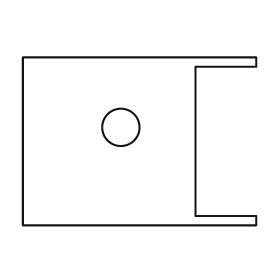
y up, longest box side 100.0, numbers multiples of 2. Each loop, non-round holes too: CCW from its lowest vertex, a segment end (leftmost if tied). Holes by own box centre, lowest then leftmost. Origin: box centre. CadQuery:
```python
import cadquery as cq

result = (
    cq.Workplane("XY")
    .moveTo(-50.0, -36.0)
    .lineTo(50.0, -36.0)
    .lineTo(50.0, -32.0)
    .lineTo(24.0, -32.0)
    .lineTo(24.0, 32.0)
    .lineTo(50.0, 32.0)
    .lineTo(50.0, 36.0)
    .lineTo(-50.0, 36.0)
    .close()
    .moveTo(-8.0, 6.0)
    .circle(8.0)
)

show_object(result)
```